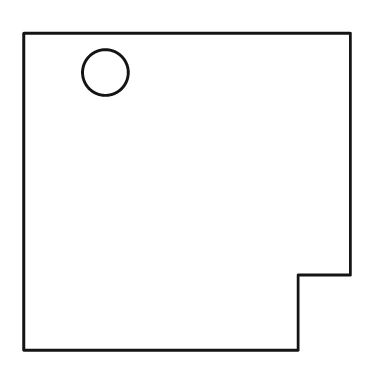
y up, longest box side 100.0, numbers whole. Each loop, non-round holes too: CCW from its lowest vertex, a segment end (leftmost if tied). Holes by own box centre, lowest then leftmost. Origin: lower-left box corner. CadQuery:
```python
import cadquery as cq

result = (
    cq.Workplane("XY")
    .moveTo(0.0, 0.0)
    .lineTo(84.0, 0.0)
    .lineTo(84.0, 23.0)
    .lineTo(100.0, 23.0)
    .lineTo(100.0, 97.0)
    .lineTo(0.0, 97.0)
    .close()
    .moveTo(25.0, 85.0)
    .circle(7.0)
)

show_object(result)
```